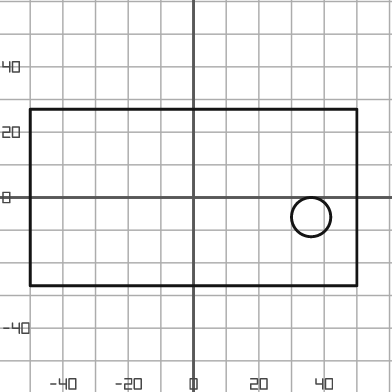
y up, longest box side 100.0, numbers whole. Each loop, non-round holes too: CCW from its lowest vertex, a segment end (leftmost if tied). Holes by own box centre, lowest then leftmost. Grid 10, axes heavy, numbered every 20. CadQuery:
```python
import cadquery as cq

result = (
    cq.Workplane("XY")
    .moveTo(-50.0, -27.0)
    .lineTo(50.0, -27.0)
    .lineTo(50.0, 27.0)
    .lineTo(-50.0, 27.0)
    .close()
    .moveTo(36.0, -6.0)
    .circle(6.0)
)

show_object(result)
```